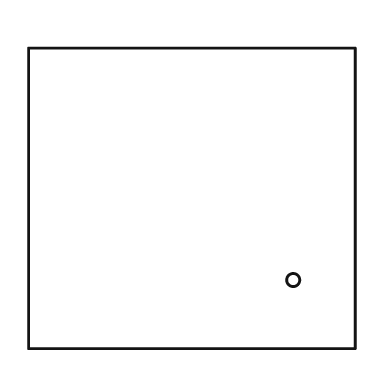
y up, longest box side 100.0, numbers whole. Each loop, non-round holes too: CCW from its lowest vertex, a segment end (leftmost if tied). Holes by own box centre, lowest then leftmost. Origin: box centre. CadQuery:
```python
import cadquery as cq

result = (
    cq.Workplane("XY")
    .moveTo(-50.0, -46.0)
    .lineTo(50.0, -46.0)
    .lineTo(50.0, 46.0)
    .lineTo(-50.0, 46.0)
    .close()
    .moveTo(31.0, -25.0)
    .circle(2.0)
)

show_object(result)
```